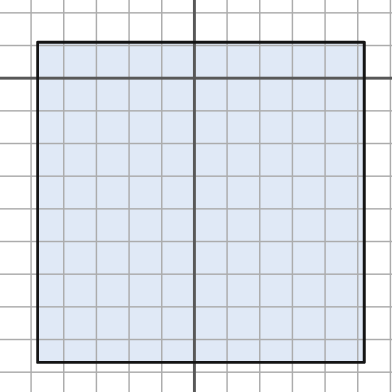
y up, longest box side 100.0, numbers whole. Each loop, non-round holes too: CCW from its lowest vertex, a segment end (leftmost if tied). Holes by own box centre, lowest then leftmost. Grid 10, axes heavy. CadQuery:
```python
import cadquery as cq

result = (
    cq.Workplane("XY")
    .moveTo(-48.0, -87.0)
    .lineTo(52.0, -87.0)
    .lineTo(52.0, 11.0)
    .lineTo(-48.0, 11.0)
    .close()
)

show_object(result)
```